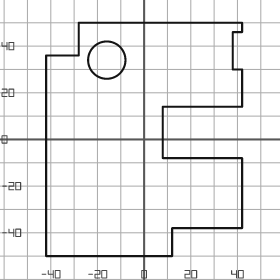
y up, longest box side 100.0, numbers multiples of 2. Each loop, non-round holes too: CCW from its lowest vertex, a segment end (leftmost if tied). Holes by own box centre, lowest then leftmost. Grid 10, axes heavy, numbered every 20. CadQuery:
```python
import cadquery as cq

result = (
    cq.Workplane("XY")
    .moveTo(-42.0, -50.0)
    .lineTo(12.0, -50.0)
    .lineTo(12.0, -38.0)
    .lineTo(42.0, -38.0)
    .lineTo(42.0, -8.0)
    .lineTo(8.0, -8.0)
    .lineTo(8.0, 14.0)
    .lineTo(42.0, 14.0)
    .lineTo(42.0, 30.0)
    .lineTo(38.0, 30.0)
    .lineTo(38.0, 46.0)
    .lineTo(42.0, 46.0)
    .lineTo(42.0, 50.0)
    .lineTo(-28.0, 50.0)
    .lineTo(-28.0, 36.0)
    .lineTo(-42.0, 36.0)
    .close()
    .moveTo(-16.0, 34.0)
    .circle(8.0)
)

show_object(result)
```